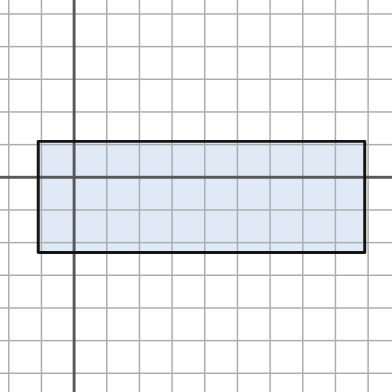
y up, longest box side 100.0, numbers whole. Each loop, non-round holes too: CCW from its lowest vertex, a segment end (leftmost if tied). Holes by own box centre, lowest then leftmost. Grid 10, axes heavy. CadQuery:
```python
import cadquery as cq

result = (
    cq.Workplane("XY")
    .moveTo(-11.0, -23.0)
    .lineTo(89.0, -23.0)
    .lineTo(89.0, 11.0)
    .lineTo(-11.0, 11.0)
    .close()
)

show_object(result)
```